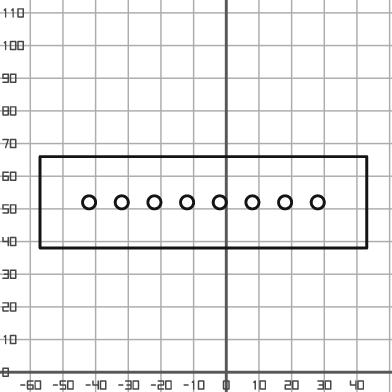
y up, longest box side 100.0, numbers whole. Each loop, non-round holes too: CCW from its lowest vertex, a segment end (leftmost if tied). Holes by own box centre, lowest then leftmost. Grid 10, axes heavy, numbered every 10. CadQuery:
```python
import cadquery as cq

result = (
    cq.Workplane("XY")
    .moveTo(-57.0, 38.0)
    .lineTo(43.0, 38.0)
    .lineTo(43.0, 66.0)
    .lineTo(-57.0, 66.0)
    .close()
    .moveTo(-42.0, 52.0)
    .circle(2.0)
    .moveTo(-32.0, 52.0)
    .circle(2.0)
    .moveTo(-22.0, 52.0)
    .circle(2.0)
    .moveTo(-12.0, 52.0)
    .circle(2.0)
    .moveTo(-2.0, 52.0)
    .circle(2.0)
    .moveTo(8.0, 52.0)
    .circle(2.0)
    .moveTo(18.0, 52.0)
    .circle(2.0)
    .moveTo(28.0, 52.0)
    .circle(2.0)
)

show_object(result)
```